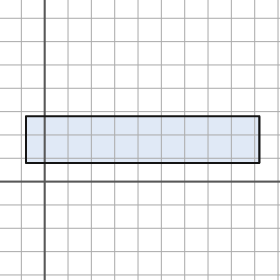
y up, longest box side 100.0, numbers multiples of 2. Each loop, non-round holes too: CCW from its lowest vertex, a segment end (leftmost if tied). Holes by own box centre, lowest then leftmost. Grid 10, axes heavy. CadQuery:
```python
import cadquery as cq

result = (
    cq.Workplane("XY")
    .moveTo(-8.0, 8.0)
    .lineTo(92.0, 8.0)
    .lineTo(92.0, 28.0)
    .lineTo(-8.0, 28.0)
    .close()
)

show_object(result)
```